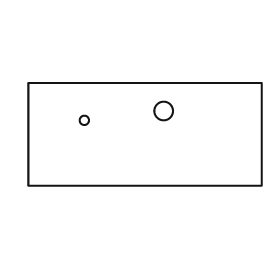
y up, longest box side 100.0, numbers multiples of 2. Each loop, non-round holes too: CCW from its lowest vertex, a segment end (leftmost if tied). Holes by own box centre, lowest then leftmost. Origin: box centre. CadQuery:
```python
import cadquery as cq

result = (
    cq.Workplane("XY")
    .moveTo(-50.0, -22.0)
    .lineTo(50.0, -22.0)
    .lineTo(50.0, 22.0)
    .lineTo(-50.0, 22.0)
    .close()
    .moveTo(-26.0, 6.0)
    .circle(2.0)
    .moveTo(8.0, 10.0)
    .circle(4.0)
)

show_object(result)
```